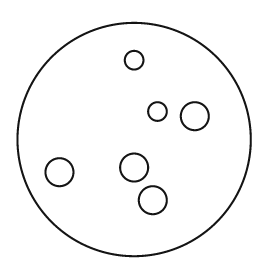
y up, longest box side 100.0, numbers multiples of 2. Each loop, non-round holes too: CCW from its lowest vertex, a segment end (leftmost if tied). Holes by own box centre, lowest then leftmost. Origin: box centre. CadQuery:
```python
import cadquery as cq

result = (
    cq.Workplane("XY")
    .moveTo(0.0, 0.0)
    .circle(50.0)
    .moveTo(8.0, -26.0)
    .circle(6.0)
    .moveTo(-32.0, -14.0)
    .circle(6.0)
    .moveTo(0.0, -12.0)
    .circle(6.0)
    .moveTo(26.0, 10.0)
    .circle(6.0)
    .moveTo(10.0, 12.0)
    .circle(4.0)
    .moveTo(0.0, 34.0)
    .circle(4.0)
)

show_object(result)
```